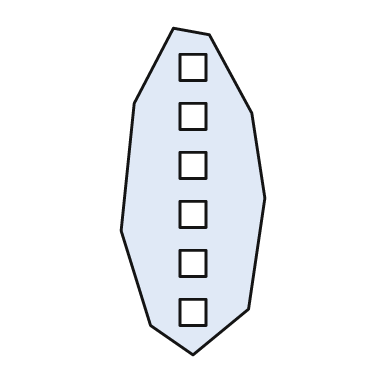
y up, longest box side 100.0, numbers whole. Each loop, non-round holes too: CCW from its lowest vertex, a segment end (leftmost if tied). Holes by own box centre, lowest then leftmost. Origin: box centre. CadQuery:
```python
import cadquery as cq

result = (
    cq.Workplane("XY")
    .moveTo(0.0, -50.0)
    .lineTo(17.0, -36.0)
    .lineTo(22.0, -2.0)
    .lineTo(18.0, 24.0)
    .lineTo(5.0, 48.0)
    .lineTo(-6.0, 50.0)
    .lineTo(-18.0, 27.0)
    .lineTo(-22.0, -12.0)
    .lineTo(-13.0, -41.0)
    .close()
    .moveTo(-4.0, -41.0)
    .lineTo(4.0, -41.0)
    .lineTo(4.0, -33.0)
    .lineTo(-4.0, -33.0)
    .close()
    .moveTo(-4.0, -26.0)
    .lineTo(4.0, -26.0)
    .lineTo(4.0, -18.0)
    .lineTo(-4.0, -18.0)
    .close()
    .moveTo(-4.0, -11.0)
    .lineTo(4.0, -11.0)
    .lineTo(4.0, -3.0)
    .lineTo(-4.0, -3.0)
    .close()
    .moveTo(-4.0, 4.0)
    .lineTo(4.0, 4.0)
    .lineTo(4.0, 12.0)
    .lineTo(-4.0, 12.0)
    .close()
    .moveTo(-4.0, 19.0)
    .lineTo(4.0, 19.0)
    .lineTo(4.0, 27.0)
    .lineTo(-4.0, 27.0)
    .close()
    .moveTo(-4.0, 34.0)
    .lineTo(4.0, 34.0)
    .lineTo(4.0, 42.0)
    .lineTo(-4.0, 42.0)
    .close()
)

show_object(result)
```